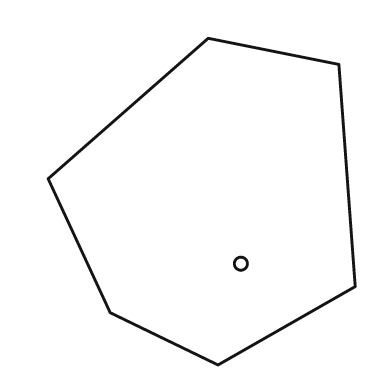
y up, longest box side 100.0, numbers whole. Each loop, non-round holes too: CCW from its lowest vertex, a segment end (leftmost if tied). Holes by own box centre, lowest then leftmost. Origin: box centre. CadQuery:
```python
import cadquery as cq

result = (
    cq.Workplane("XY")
    .moveTo(5.0, -50.0)
    .lineTo(47.0, -26.0)
    .lineTo(42.0, 42.0)
    .lineTo(2.0, 50.0)
    .lineTo(-47.0, 7.0)
    .lineTo(-28.0, -34.0)
    .close()
    .moveTo(12.0, -19.0)
    .circle(2.0)
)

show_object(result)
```